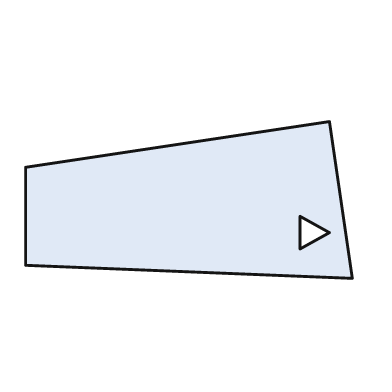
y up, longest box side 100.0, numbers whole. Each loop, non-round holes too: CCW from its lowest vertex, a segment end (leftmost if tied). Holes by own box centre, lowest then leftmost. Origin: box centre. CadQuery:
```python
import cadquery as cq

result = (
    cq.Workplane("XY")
    .moveTo(50.0, -24.0)
    .lineTo(43.0, 24.0)
    .lineTo(-50.0, 10.0)
    .lineTo(-50.0, -20.0)
    .close()
    .moveTo(34.0, -15.0)
    .lineTo(43.0, -10.0)
    .lineTo(34.0, -5.0)
    .close()
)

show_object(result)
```